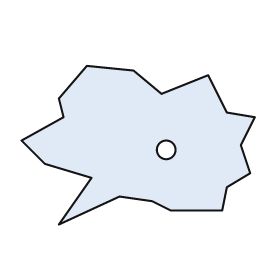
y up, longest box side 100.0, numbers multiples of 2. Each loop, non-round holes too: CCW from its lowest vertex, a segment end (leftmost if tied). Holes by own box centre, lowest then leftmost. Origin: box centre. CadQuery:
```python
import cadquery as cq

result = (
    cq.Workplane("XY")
    .moveTo(-34.0, -34.0)
    .lineTo(-8.0, -22.0)
    .lineTo(6.0, -24.0)
    .lineTo(14.0, -28.0)
    .lineTo(36.0, -28.0)
    .lineTo(38.0, -18.0)
    .lineTo(48.0, -12.0)
    .lineTo(44.0, 0.0)
    .lineTo(50.0, 12.0)
    .lineTo(38.0, 14.0)
    .lineTo(30.0, 30.0)
    .lineTo(10.0, 22.0)
    .lineTo(-2.0, 32.0)
    .lineTo(-22.0, 34.0)
    .lineTo(-34.0, 20.0)
    .lineTo(-32.0, 12.0)
    .lineTo(-50.0, 2.0)
    .lineTo(-40.0, -8.0)
    .lineTo(-20.0, -14.0)
    .close()
    .moveTo(12.0, -2.0)
    .circle(4.0)
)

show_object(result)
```